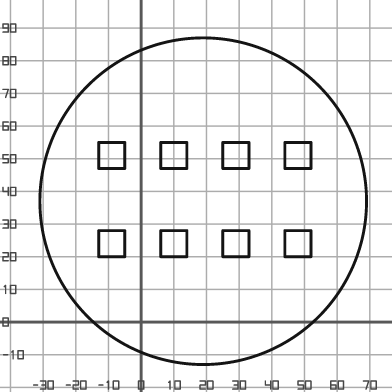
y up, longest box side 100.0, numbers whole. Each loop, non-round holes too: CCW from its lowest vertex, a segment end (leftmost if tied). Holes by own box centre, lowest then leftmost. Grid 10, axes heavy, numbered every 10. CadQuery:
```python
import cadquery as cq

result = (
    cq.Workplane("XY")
    .moveTo(19.0, 37.0)
    .circle(50.0)
    .moveTo(-13.0, 20.0)
    .lineTo(-5.0, 20.0)
    .lineTo(-5.0, 28.0)
    .lineTo(-13.0, 28.0)
    .close()
    .moveTo(6.0, 20.0)
    .lineTo(14.0, 20.0)
    .lineTo(14.0, 28.0)
    .lineTo(6.0, 28.0)
    .close()
    .moveTo(25.0, 20.0)
    .lineTo(33.0, 20.0)
    .lineTo(33.0, 28.0)
    .lineTo(25.0, 28.0)
    .close()
    .moveTo(44.0, 20.0)
    .lineTo(52.0, 20.0)
    .lineTo(52.0, 28.0)
    .lineTo(44.0, 28.0)
    .close()
    .moveTo(-13.0, 47.0)
    .lineTo(-5.0, 47.0)
    .lineTo(-5.0, 55.0)
    .lineTo(-13.0, 55.0)
    .close()
    .moveTo(6.0, 47.0)
    .lineTo(14.0, 47.0)
    .lineTo(14.0, 55.0)
    .lineTo(6.0, 55.0)
    .close()
    .moveTo(25.0, 47.0)
    .lineTo(33.0, 47.0)
    .lineTo(33.0, 55.0)
    .lineTo(25.0, 55.0)
    .close()
    .moveTo(44.0, 47.0)
    .lineTo(52.0, 47.0)
    .lineTo(52.0, 55.0)
    .lineTo(44.0, 55.0)
    .close()
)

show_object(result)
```